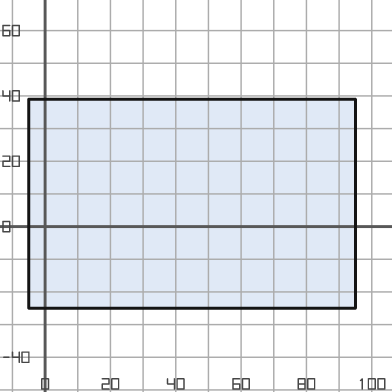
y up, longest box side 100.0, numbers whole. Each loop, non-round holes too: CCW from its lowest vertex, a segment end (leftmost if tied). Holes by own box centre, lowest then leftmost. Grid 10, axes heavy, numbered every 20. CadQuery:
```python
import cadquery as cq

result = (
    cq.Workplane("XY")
    .moveTo(-5.0, -25.0)
    .lineTo(95.0, -25.0)
    .lineTo(95.0, 39.0)
    .lineTo(-5.0, 39.0)
    .close()
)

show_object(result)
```